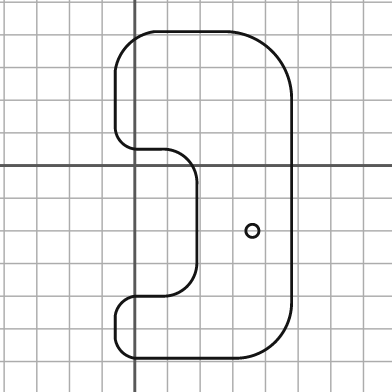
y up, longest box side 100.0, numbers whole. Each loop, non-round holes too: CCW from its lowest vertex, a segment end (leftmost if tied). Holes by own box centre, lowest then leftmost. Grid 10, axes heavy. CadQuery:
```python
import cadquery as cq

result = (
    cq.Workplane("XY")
    .moveTo(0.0, -59.0)
    .lineTo(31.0, -59.0)
    .threePointArc((43.0, -54.0), (48.0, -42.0))
    .lineTo(48.0, 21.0)
    .threePointArc((42.0, 35.0), (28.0, 41.0))
    .lineTo(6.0, 41.0)
    .threePointArc((-2.0, 37.0), (-6.0, 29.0))
    .lineTo(-6.0, 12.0)
    .threePointArc((-4.0, 7.0), (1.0, 5.0))
    .lineTo(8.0, 5.0)
    .threePointArc((16.0, 2.0), (19.0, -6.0))
    .lineTo(19.0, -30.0)
    .threePointArc((16.0, -37.0), (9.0, -40.0))
    .lineTo(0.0, -40.0)
    .threePointArc((-4.0, -42.0), (-6.0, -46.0))
    .lineTo(-6.0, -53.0)
    .threePointArc((-4.0, -57.0), (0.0, -59.0))
    .close()
    .moveTo(36.0, -20.0)
    .circle(2.0)
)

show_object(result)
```